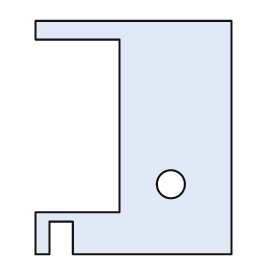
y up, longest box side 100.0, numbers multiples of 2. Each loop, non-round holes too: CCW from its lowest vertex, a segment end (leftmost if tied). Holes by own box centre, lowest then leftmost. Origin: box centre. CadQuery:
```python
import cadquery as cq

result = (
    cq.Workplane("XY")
    .moveTo(-42.0, -50.0)
    .lineTo(-36.0, -50.0)
    .lineTo(-36.0, -36.0)
    .lineTo(-26.0, -36.0)
    .lineTo(-26.0, -50.0)
    .lineTo(42.0, -50.0)
    .lineTo(42.0, 50.0)
    .lineTo(-42.0, 50.0)
    .lineTo(-42.0, 42.0)
    .lineTo(-6.0, 42.0)
    .lineTo(-6.0, -32.0)
    .lineTo(-42.0, -32.0)
    .close()
    .moveTo(16.0, -20.0)
    .circle(6.0)
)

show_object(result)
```